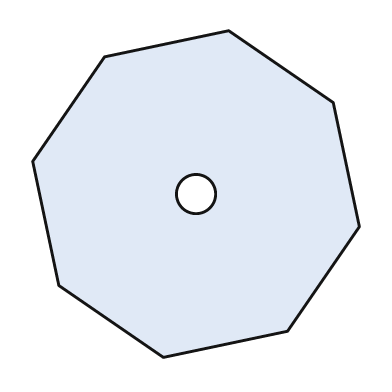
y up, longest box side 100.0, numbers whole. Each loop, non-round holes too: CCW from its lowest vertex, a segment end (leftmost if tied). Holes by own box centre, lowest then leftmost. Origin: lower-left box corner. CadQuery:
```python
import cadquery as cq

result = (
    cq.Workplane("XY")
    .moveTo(40.0, 0.0)
    .lineTo(78.0, 8.0)
    .lineTo(100.0, 40.0)
    .lineTo(92.0, 78.0)
    .lineTo(60.0, 100.0)
    .lineTo(22.0, 92.0)
    .lineTo(0.0, 60.0)
    .lineTo(8.0, 22.0)
    .close()
    .moveTo(50.0, 50.0)
    .circle(6.0)
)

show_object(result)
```